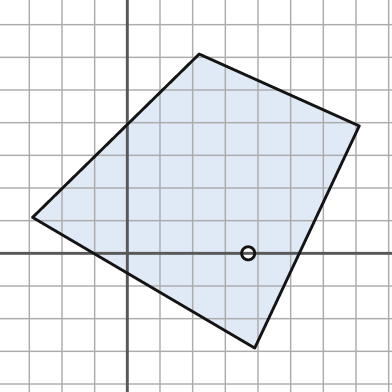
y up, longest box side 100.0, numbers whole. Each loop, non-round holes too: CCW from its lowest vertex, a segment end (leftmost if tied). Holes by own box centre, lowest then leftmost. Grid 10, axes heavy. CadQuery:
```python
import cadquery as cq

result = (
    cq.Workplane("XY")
    .moveTo(39.0, -29.0)
    .lineTo(71.0, 39.0)
    .lineTo(22.0, 61.0)
    .lineTo(-29.0, 11.0)
    .close()
    .moveTo(37.0, 0.0)
    .circle(2.0)
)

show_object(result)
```